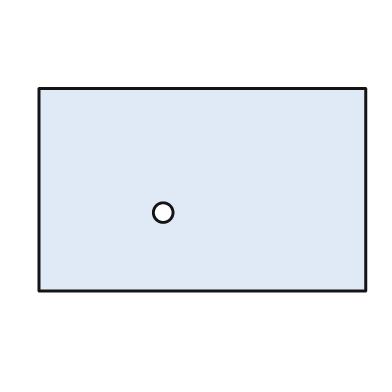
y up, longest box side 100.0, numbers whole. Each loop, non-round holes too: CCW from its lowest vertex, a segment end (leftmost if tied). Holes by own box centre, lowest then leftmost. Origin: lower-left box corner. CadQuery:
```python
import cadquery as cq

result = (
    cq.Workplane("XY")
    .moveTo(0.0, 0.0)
    .lineTo(100.0, 0.0)
    .lineTo(100.0, 62.0)
    .lineTo(0.0, 62.0)
    .close()
    .moveTo(38.0, 24.0)
    .circle(3.0)
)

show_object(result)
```